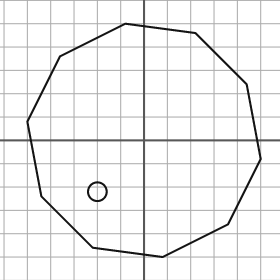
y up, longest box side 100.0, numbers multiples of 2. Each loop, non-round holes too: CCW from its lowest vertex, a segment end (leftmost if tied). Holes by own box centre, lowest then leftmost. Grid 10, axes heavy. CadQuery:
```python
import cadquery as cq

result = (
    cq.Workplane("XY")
    .moveTo(8.0, -50.0)
    .lineTo(36.0, -36.0)
    .lineTo(50.0, -8.0)
    .lineTo(44.0, 24.0)
    .lineTo(22.0, 46.0)
    .lineTo(-8.0, 50.0)
    .lineTo(-36.0, 36.0)
    .lineTo(-50.0, 8.0)
    .lineTo(-44.0, -24.0)
    .lineTo(-22.0, -46.0)
    .close()
    .moveTo(-20.0, -22.0)
    .circle(4.0)
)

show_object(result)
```